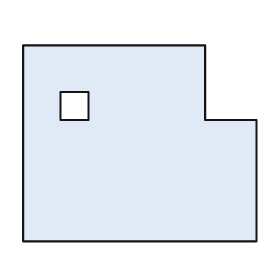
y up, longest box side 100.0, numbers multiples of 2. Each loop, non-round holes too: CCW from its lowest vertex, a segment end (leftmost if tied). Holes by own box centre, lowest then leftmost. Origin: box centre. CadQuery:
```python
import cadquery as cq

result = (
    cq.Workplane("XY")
    .moveTo(-50.0, -42.0)
    .lineTo(50.0, -42.0)
    .lineTo(50.0, 10.0)
    .lineTo(28.0, 10.0)
    .lineTo(28.0, 42.0)
    .lineTo(-50.0, 42.0)
    .close()
    .moveTo(-34.0, 10.0)
    .lineTo(-22.0, 10.0)
    .lineTo(-22.0, 22.0)
    .lineTo(-34.0, 22.0)
    .close()
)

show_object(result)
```